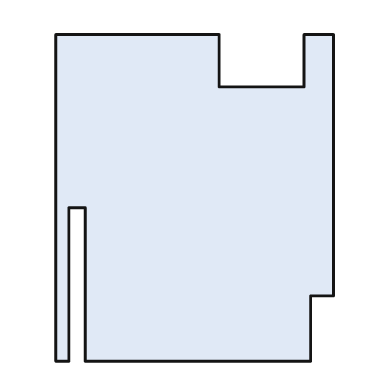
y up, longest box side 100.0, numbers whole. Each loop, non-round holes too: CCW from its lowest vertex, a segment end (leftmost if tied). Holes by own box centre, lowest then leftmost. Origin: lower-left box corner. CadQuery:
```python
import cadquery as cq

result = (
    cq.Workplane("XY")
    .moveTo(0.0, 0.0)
    .lineTo(4.0, 0.0)
    .lineTo(4.0, 47.0)
    .lineTo(9.0, 47.0)
    .lineTo(9.0, 0.0)
    .lineTo(78.0, 0.0)
    .lineTo(78.0, 20.0)
    .lineTo(85.0, 20.0)
    .lineTo(85.0, 100.0)
    .lineTo(76.0, 100.0)
    .lineTo(76.0, 84.0)
    .lineTo(50.0, 84.0)
    .lineTo(50.0, 100.0)
    .lineTo(0.0, 100.0)
    .close()
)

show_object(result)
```